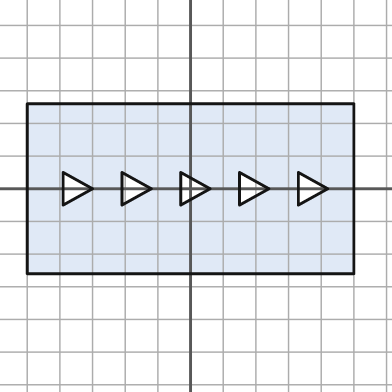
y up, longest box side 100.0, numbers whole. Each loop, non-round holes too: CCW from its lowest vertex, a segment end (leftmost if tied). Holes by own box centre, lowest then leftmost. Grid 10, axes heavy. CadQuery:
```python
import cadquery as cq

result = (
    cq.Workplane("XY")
    .moveTo(-50.0, -26.0)
    .lineTo(50.0, -26.0)
    .lineTo(50.0, 26.0)
    .lineTo(-50.0, 26.0)
    .close()
    .moveTo(-39.0, -5.0)
    .lineTo(-30.0, 0.0)
    .lineTo(-39.0, 5.0)
    .close()
    .moveTo(-21.0, -5.0)
    .lineTo(-12.0, 0.0)
    .lineTo(-21.0, 5.0)
    .close()
    .moveTo(-3.0, -5.0)
    .lineTo(6.0, 0.0)
    .lineTo(-3.0, 5.0)
    .close()
    .moveTo(15.0, -5.0)
    .lineTo(24.0, 0.0)
    .lineTo(15.0, 5.0)
    .close()
    .moveTo(33.0, -5.0)
    .lineTo(42.0, 0.0)
    .lineTo(33.0, 5.0)
    .close()
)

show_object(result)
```